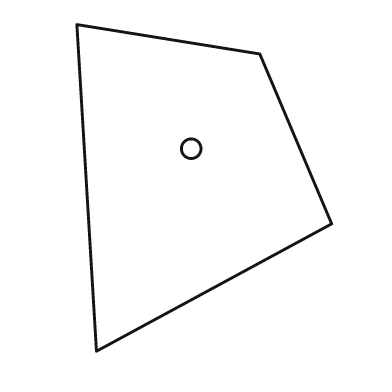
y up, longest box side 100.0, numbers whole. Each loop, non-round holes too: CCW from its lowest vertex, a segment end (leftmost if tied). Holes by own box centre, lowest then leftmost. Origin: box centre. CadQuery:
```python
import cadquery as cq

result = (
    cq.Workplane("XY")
    .moveTo(-33.0, -50.0)
    .lineTo(39.0, -11.0)
    .lineTo(17.0, 41.0)
    .lineTo(-39.0, 50.0)
    .close()
    .moveTo(-4.0, 12.0)
    .circle(3.0)
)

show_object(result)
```